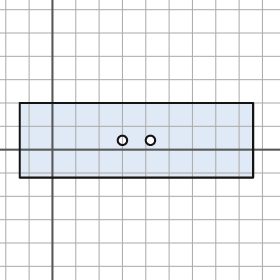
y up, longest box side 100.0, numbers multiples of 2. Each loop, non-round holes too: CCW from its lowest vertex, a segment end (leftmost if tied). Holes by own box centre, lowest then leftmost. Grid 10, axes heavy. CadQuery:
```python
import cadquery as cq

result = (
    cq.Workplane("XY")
    .moveTo(-14.0, -12.0)
    .lineTo(86.0, -12.0)
    .lineTo(86.0, 20.0)
    .lineTo(-14.0, 20.0)
    .close()
    .moveTo(30.0, 4.0)
    .circle(2.0)
    .moveTo(42.0, 4.0)
    .circle(2.0)
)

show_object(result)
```